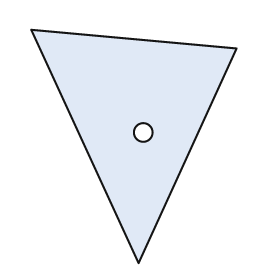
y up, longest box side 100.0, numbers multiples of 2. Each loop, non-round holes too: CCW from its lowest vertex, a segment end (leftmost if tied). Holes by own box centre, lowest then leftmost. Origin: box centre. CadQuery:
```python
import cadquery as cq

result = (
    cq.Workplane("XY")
    .moveTo(2.0, -50.0)
    .lineTo(44.0, 42.0)
    .lineTo(-44.0, 50.0)
    .close()
    .moveTo(4.0, 6.0)
    .circle(4.0)
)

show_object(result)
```